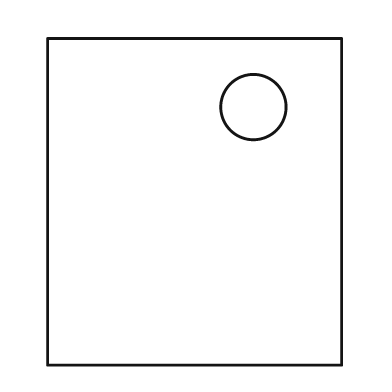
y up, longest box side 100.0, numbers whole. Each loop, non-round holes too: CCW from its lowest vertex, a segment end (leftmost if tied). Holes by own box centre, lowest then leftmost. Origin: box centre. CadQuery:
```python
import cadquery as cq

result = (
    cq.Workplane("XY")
    .moveTo(-45.0, -50.0)
    .lineTo(45.0, -50.0)
    .lineTo(45.0, 50.0)
    .lineTo(-45.0, 50.0)
    .close()
    .moveTo(18.0, 29.0)
    .circle(10.0)
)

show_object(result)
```